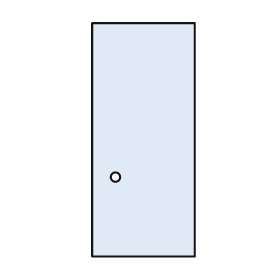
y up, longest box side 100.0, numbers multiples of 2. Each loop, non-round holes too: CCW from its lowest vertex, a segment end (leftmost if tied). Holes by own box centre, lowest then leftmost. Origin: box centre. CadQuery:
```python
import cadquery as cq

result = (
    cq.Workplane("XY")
    .moveTo(-22.0, -50.0)
    .lineTo(22.0, -50.0)
    .lineTo(22.0, 50.0)
    .lineTo(-22.0, 50.0)
    .close()
    .moveTo(-12.0, -16.0)
    .circle(2.0)
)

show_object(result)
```